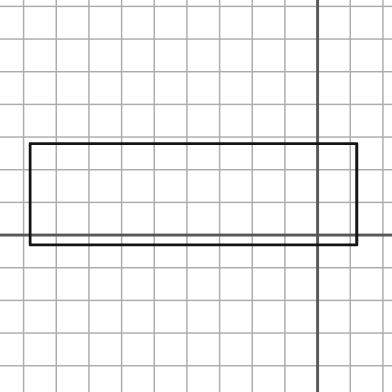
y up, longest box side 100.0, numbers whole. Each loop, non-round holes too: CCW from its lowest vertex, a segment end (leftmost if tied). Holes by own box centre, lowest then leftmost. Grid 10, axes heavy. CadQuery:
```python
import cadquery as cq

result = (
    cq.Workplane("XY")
    .moveTo(-88.0, -3.0)
    .lineTo(12.0, -3.0)
    .lineTo(12.0, 28.0)
    .lineTo(-88.0, 28.0)
    .close()
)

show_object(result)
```